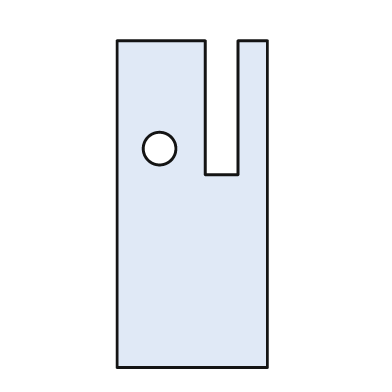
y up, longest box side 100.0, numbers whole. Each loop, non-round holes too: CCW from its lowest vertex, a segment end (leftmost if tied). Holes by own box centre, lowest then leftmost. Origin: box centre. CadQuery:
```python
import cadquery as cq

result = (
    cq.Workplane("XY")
    .moveTo(-23.0, -50.0)
    .lineTo(23.0, -50.0)
    .lineTo(23.0, 50.0)
    .lineTo(14.0, 50.0)
    .lineTo(14.0, 9.0)
    .lineTo(4.0, 9.0)
    .lineTo(4.0, 50.0)
    .lineTo(-23.0, 50.0)
    .close()
    .moveTo(-10.0, 17.0)
    .circle(5.0)
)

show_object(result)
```